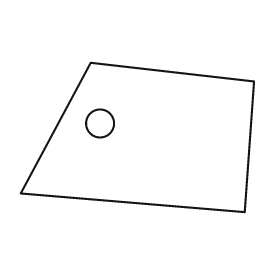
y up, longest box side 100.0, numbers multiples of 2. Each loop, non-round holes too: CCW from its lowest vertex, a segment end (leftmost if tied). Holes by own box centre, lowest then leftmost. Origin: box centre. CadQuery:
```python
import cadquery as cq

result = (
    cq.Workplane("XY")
    .moveTo(46.0, -32.0)
    .lineTo(50.0, 24.0)
    .lineTo(-20.0, 32.0)
    .lineTo(-50.0, -24.0)
    .close()
    .moveTo(-16.0, 6.0)
    .circle(6.0)
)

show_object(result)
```